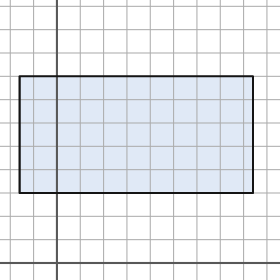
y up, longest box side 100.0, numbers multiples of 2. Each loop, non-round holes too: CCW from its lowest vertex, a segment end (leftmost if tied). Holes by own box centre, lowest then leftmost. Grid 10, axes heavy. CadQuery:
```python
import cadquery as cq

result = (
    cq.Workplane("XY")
    .moveTo(-16.0, 30.0)
    .lineTo(84.0, 30.0)
    .lineTo(84.0, 80.0)
    .lineTo(-16.0, 80.0)
    .close()
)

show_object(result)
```